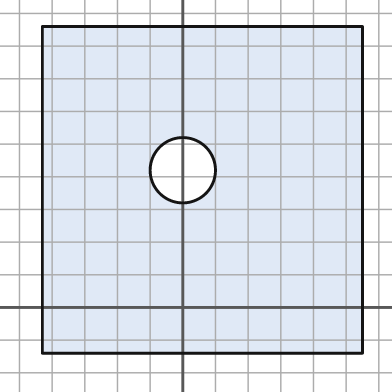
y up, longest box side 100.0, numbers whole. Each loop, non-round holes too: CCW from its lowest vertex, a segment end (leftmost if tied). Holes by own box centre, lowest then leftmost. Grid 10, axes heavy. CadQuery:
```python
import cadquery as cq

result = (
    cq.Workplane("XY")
    .moveTo(-43.0, -14.0)
    .lineTo(55.0, -14.0)
    .lineTo(55.0, 86.0)
    .lineTo(-43.0, 86.0)
    .close()
    .moveTo(0.0, 42.0)
    .circle(10.0)
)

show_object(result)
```